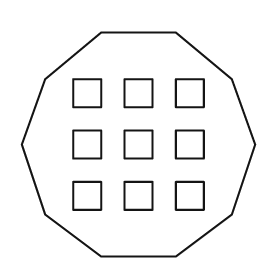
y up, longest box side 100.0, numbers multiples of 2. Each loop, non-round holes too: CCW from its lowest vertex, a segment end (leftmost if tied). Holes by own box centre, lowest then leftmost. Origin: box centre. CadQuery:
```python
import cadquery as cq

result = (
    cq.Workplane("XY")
    .moveTo(-16.0, -48.0)
    .lineTo(16.0, -48.0)
    .lineTo(40.0, -30.0)
    .lineTo(50.0, 0.0)
    .lineTo(40.0, 28.0)
    .lineTo(16.0, 48.0)
    .lineTo(-16.0, 48.0)
    .lineTo(-40.0, 28.0)
    .lineTo(-50.0, 0.0)
    .lineTo(-40.0, -30.0)
    .close()
    .moveTo(-28.0, -28.0)
    .lineTo(-16.0, -28.0)
    .lineTo(-16.0, -16.0)
    .lineTo(-28.0, -16.0)
    .close()
    .moveTo(-6.0, -28.0)
    .lineTo(6.0, -28.0)
    .lineTo(6.0, -16.0)
    .lineTo(-6.0, -16.0)
    .close()
    .moveTo(16.0, -28.0)
    .lineTo(28.0, -28.0)
    .lineTo(28.0, -16.0)
    .lineTo(16.0, -16.0)
    .close()
    .moveTo(-28.0, -6.0)
    .lineTo(-16.0, -6.0)
    .lineTo(-16.0, 6.0)
    .lineTo(-28.0, 6.0)
    .close()
    .moveTo(-6.0, -6.0)
    .lineTo(6.0, -6.0)
    .lineTo(6.0, 6.0)
    .lineTo(-6.0, 6.0)
    .close()
    .moveTo(16.0, -6.0)
    .lineTo(28.0, -6.0)
    .lineTo(28.0, 6.0)
    .lineTo(16.0, 6.0)
    .close()
    .moveTo(-28.0, 16.0)
    .lineTo(-16.0, 16.0)
    .lineTo(-16.0, 28.0)
    .lineTo(-28.0, 28.0)
    .close()
    .moveTo(-6.0, 16.0)
    .lineTo(6.0, 16.0)
    .lineTo(6.0, 28.0)
    .lineTo(-6.0, 28.0)
    .close()
    .moveTo(16.0, 16.0)
    .lineTo(28.0, 16.0)
    .lineTo(28.0, 28.0)
    .lineTo(16.0, 28.0)
    .close()
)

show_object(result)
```